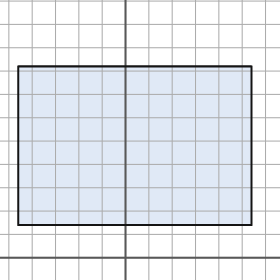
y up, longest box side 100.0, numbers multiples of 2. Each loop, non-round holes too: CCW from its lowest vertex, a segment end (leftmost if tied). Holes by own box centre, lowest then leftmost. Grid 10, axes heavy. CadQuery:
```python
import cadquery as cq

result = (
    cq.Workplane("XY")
    .moveTo(-46.0, 14.0)
    .lineTo(54.0, 14.0)
    .lineTo(54.0, 82.0)
    .lineTo(-46.0, 82.0)
    .close()
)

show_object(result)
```